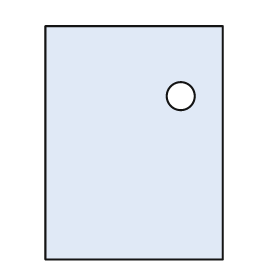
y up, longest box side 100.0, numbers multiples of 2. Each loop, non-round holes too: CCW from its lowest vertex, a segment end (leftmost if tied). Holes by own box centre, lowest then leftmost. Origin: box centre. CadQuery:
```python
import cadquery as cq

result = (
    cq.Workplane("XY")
    .moveTo(-38.0, -50.0)
    .lineTo(38.0, -50.0)
    .lineTo(38.0, 50.0)
    .lineTo(-38.0, 50.0)
    .close()
    .moveTo(20.0, 20.0)
    .circle(6.0)
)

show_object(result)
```